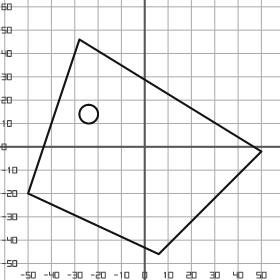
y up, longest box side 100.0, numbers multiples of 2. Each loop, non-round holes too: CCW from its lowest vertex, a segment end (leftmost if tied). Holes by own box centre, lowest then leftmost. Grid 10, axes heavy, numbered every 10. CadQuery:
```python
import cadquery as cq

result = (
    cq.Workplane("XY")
    .moveTo(6.0, -46.0)
    .lineTo(50.0, -2.0)
    .lineTo(-28.0, 46.0)
    .lineTo(-50.0, -20.0)
    .close()
    .moveTo(-24.0, 14.0)
    .circle(4.0)
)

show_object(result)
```